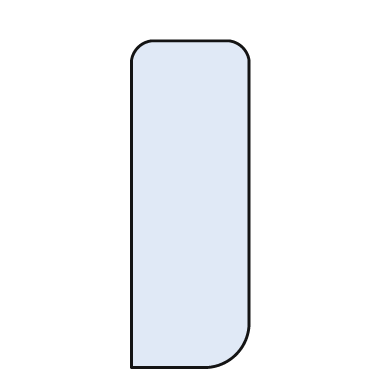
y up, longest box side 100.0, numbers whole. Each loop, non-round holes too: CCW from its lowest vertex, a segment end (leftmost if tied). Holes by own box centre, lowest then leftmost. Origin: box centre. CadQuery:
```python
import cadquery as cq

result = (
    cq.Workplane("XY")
    .moveTo(-18.0, -50.0)
    .lineTo(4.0, -50.0)
    .threePointArc((14.0, -46.0), (18.0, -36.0))
    .lineTo(18.0, 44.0)
    .threePointArc((16.0, 48.0), (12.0, 50.0))
    .lineTo(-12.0, 50.0)
    .threePointArc((-16.0, 48.0), (-18.0, 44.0))
    .close()
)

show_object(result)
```